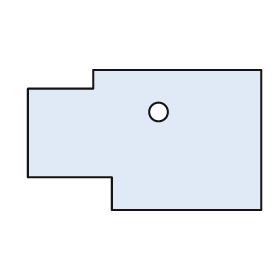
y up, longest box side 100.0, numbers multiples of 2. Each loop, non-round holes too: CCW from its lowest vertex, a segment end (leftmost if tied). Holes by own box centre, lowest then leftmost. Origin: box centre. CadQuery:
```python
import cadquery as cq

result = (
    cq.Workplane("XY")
    .moveTo(-14.0, -30.0)
    .lineTo(50.0, -30.0)
    .lineTo(50.0, 30.0)
    .lineTo(-22.0, 30.0)
    .lineTo(-22.0, 22.0)
    .lineTo(-50.0, 22.0)
    .lineTo(-50.0, -16.0)
    .lineTo(-14.0, -16.0)
    .close()
    .moveTo(6.0, 12.0)
    .circle(4.0)
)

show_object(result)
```